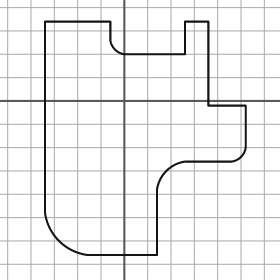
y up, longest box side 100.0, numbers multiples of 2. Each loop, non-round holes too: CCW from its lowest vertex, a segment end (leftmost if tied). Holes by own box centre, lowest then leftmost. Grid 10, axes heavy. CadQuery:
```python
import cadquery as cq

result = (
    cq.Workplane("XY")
    .moveTo(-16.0, -66.0)
    .lineTo(14.0, -66.0)
    .lineTo(14.0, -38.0)
    .threePointArc((18.0, -30.0), (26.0, -26.0))
    .lineTo(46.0, -26.0)
    .threePointArc((50.0, -24.0), (52.0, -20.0))
    .lineTo(52.0, -2.0)
    .lineTo(36.0, -2.0)
    .lineTo(36.0, 34.0)
    .lineTo(26.0, 34.0)
    .lineTo(26.0, 20.0)
    .lineTo(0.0, 20.0)
    .threePointArc((-4.0, 22.0), (-6.0, 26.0))
    .lineTo(-6.0, 34.0)
    .lineTo(-34.0, 34.0)
    .lineTo(-34.0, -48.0)
    .threePointArc((-28.0, -60.0), (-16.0, -66.0))
    .close()
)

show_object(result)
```